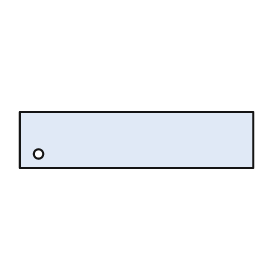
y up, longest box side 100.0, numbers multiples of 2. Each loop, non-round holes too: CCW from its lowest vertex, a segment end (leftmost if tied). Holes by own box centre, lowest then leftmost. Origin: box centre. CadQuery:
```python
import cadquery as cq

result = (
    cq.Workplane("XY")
    .moveTo(-50.0, -12.0)
    .lineTo(50.0, -12.0)
    .lineTo(50.0, 12.0)
    .lineTo(-50.0, 12.0)
    .close()
    .moveTo(-42.0, -6.0)
    .circle(2.0)
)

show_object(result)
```